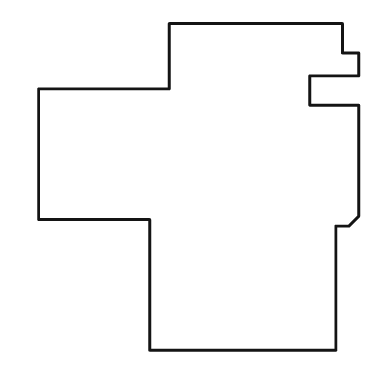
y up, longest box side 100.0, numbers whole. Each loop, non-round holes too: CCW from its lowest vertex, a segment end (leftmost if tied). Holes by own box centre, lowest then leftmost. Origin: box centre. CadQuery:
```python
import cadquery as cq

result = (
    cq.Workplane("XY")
    .moveTo(-15.0, -50.0)
    .lineTo(42.0, -50.0)
    .lineTo(42.0, -12.0)
    .lineTo(46.0, -12.0)
    .lineTo(49.0, -9.0)
    .lineTo(49.0, 25.0)
    .lineTo(34.0, 25.0)
    .lineTo(34.0, 34.0)
    .lineTo(49.0, 34.0)
    .lineTo(49.0, 41.0)
    .lineTo(44.0, 41.0)
    .lineTo(44.0, 50.0)
    .lineTo(-9.0, 50.0)
    .lineTo(-9.0, 30.0)
    .lineTo(-49.0, 30.0)
    .lineTo(-49.0, -10.0)
    .lineTo(-15.0, -10.0)
    .close()
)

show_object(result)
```